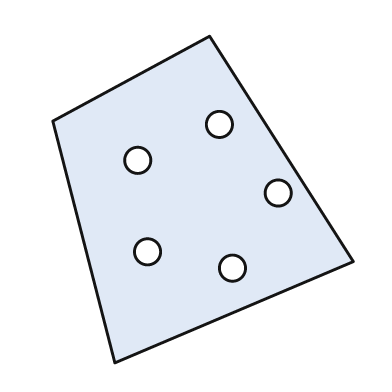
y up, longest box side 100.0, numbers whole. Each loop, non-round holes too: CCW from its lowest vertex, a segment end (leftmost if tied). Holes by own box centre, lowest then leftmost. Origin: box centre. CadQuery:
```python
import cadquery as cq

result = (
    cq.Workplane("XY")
    .moveTo(-27.0, -50.0)
    .lineTo(46.0, -19.0)
    .lineTo(2.0, 50.0)
    .lineTo(-46.0, 24.0)
    .close()
    .moveTo(9.0, -21.0)
    .circle(4.0)
    .moveTo(-17.0, -16.0)
    .circle(4.0)
    .moveTo(23.0, 2.0)
    .circle(4.0)
    .moveTo(-20.0, 12.0)
    .circle(4.0)
    .moveTo(5.0, 23.0)
    .circle(4.0)
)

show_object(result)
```